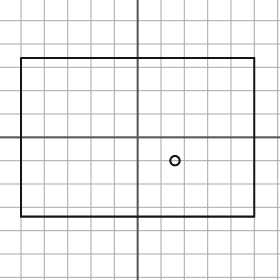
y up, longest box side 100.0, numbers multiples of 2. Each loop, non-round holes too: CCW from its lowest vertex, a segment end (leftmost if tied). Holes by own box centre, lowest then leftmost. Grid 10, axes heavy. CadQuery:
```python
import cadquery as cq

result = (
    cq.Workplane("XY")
    .moveTo(-50.0, -34.0)
    .lineTo(50.0, -34.0)
    .lineTo(50.0, 34.0)
    .lineTo(-50.0, 34.0)
    .close()
    .moveTo(16.0, -10.0)
    .circle(2.0)
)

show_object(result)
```